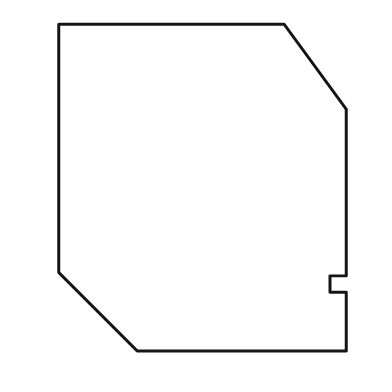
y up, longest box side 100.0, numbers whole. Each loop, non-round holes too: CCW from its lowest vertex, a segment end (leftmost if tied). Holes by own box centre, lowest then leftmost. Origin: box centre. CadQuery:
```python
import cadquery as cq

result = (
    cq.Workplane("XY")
    .moveTo(-20.0, -50.0)
    .lineTo(44.0, -50.0)
    .lineTo(44.0, -32.0)
    .lineTo(39.0, -32.0)
    .lineTo(39.0, -27.0)
    .lineTo(44.0, -27.0)
    .lineTo(44.0, 24.0)
    .lineTo(25.0, 50.0)
    .lineTo(-44.0, 50.0)
    .lineTo(-44.0, -26.0)
    .close()
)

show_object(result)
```